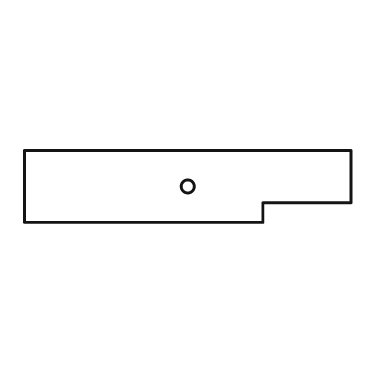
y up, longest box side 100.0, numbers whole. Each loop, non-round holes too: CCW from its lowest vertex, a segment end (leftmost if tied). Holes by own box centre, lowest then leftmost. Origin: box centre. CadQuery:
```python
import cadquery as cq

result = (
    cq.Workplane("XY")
    .moveTo(-50.0, -11.0)
    .lineTo(23.0, -11.0)
    .lineTo(23.0, -5.0)
    .lineTo(50.0, -5.0)
    .lineTo(50.0, 11.0)
    .lineTo(-50.0, 11.0)
    .close()
    .moveTo(0.0, 0.0)
    .circle(2.0)
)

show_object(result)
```